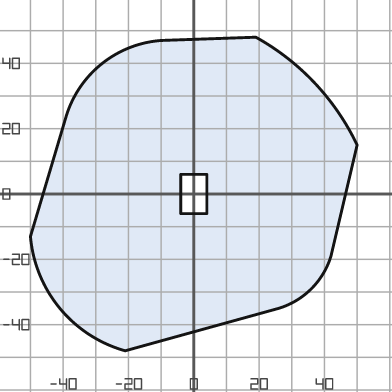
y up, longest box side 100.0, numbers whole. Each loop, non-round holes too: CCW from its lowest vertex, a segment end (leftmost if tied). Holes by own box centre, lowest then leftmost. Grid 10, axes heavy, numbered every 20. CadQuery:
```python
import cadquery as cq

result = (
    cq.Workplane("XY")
    .moveTo(-21.0, -48.0)
    .lineTo(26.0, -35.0)
    .threePointArc((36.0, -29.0), (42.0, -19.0))
    .lineTo(50.0, 15.0)
    .threePointArc((37.0, 34.0), (19.0, 48.0))
    .lineTo(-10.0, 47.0)
    .threePointArc((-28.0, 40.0), (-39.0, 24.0))
    .lineTo(-50.0, -13.0)
    .threePointArc((-41.0, -35.0), (-21.0, -48.0))
    .close()
    .moveTo(-4.0, -6.0)
    .lineTo(4.0, -6.0)
    .lineTo(4.0, 6.0)
    .lineTo(-4.0, 6.0)
    .close()
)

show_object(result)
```